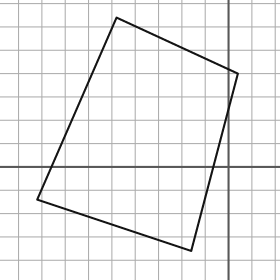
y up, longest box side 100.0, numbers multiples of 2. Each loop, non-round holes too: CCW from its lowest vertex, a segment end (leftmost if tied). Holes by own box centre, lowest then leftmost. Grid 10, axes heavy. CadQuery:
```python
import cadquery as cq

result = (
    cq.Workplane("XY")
    .moveTo(-16.0, -36.0)
    .lineTo(4.0, 40.0)
    .lineTo(-48.0, 64.0)
    .lineTo(-82.0, -14.0)
    .close()
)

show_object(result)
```